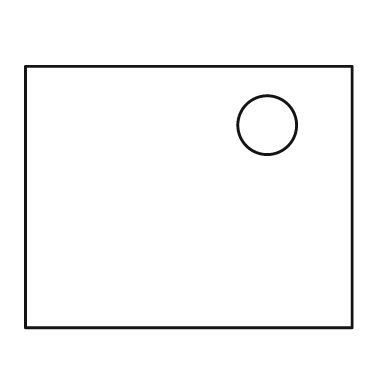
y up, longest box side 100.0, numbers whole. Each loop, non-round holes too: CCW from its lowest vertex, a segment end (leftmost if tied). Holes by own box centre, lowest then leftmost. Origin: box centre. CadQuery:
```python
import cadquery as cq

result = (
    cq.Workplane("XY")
    .moveTo(-50.0, -40.0)
    .lineTo(50.0, -40.0)
    .lineTo(50.0, 40.0)
    .lineTo(-50.0, 40.0)
    .close()
    .moveTo(24.0, 22.0)
    .circle(9.0)
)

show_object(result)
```